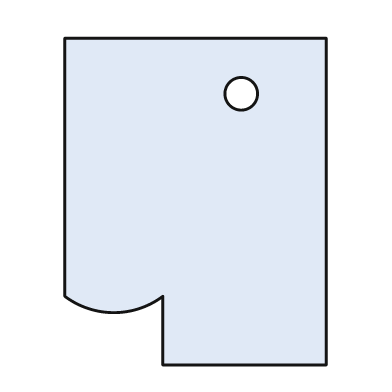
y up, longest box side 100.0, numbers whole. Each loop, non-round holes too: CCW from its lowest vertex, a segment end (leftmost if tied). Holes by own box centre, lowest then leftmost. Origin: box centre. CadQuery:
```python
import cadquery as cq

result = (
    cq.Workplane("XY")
    .moveTo(-10.0, -50.0)
    .lineTo(40.0, -50.0)
    .lineTo(40.0, 50.0)
    .lineTo(-40.0, 50.0)
    .lineTo(-40.0, -29.0)
    .threePointArc((-25.0, -34.0), (-10.0, -29.0))
    .close()
    .moveTo(14.0, 33.0)
    .circle(5.0)
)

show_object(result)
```